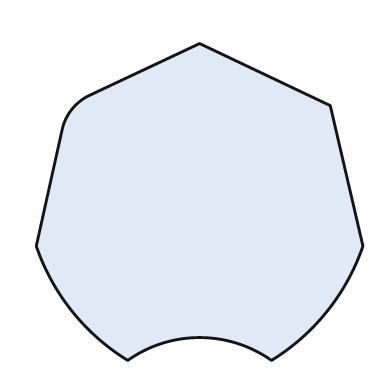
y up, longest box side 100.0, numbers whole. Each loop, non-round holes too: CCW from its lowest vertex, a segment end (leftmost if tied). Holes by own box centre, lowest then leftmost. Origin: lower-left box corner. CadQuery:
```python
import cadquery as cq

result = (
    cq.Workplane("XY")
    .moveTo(28.0, 0.0)
    .threePointArc((50.0, 7.0), (72.0, 0.0))
    .threePointArc((89.0, 15.0), (100.0, 35.0))
    .lineTo(90.0, 78.0)
    .lineTo(50.0, 97.0)
    .lineTo(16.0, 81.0)
    .threePointArc((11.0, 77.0), (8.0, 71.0))
    .lineTo(0.0, 35.0)
    .threePointArc((11.0, 15.0), (28.0, 0.0))
    .close()
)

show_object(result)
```